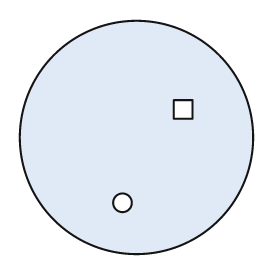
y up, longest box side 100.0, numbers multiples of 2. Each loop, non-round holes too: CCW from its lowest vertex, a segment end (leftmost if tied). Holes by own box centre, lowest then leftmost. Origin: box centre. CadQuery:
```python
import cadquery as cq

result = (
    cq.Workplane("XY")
    .moveTo(0.0, 0.0)
    .circle(50.0)
    .moveTo(-6.0, -28.0)
    .circle(4.0)
    .moveTo(16.0, 8.0)
    .lineTo(24.0, 8.0)
    .lineTo(24.0, 16.0)
    .lineTo(16.0, 16.0)
    .close()
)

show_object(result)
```